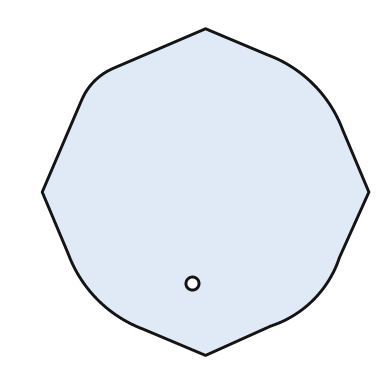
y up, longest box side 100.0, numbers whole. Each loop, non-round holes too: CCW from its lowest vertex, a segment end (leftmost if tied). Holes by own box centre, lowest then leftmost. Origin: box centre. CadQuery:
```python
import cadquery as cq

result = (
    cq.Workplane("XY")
    .moveTo(0.0, -50.0)
    .lineTo(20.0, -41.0)
    .threePointArc((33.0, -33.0), (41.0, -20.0))
    .lineTo(50.0, 0.0)
    .lineTo(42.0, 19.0)
    .threePointArc((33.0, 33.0), (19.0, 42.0))
    .lineTo(0.0, 50.0)
    .lineTo(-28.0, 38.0)
    .threePointArc((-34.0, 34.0), (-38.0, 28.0))
    .lineTo(-50.0, 0.0)
    .lineTo(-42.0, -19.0)
    .threePointArc((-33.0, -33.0), (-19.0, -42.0))
    .close()
    .moveTo(-4.0, -28.0)
    .circle(2.0)
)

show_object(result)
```